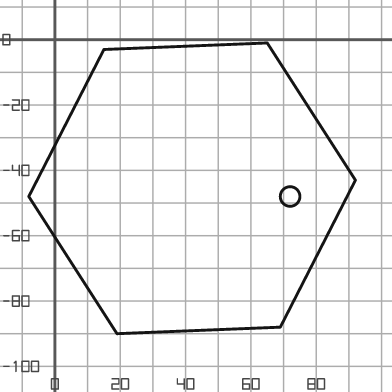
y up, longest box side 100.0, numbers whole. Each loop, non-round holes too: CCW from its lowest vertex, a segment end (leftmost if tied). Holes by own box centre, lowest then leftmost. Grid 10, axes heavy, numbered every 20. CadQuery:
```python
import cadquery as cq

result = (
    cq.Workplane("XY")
    .moveTo(19.0, -90.0)
    .lineTo(69.0, -88.0)
    .lineTo(92.0, -43.0)
    .lineTo(65.0, -1.0)
    .lineTo(15.0, -3.0)
    .lineTo(-8.0, -48.0)
    .close()
    .moveTo(72.0, -48.0)
    .circle(3.0)
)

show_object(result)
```